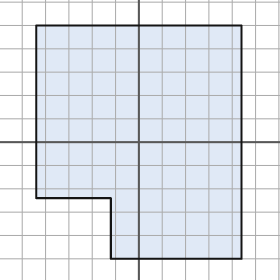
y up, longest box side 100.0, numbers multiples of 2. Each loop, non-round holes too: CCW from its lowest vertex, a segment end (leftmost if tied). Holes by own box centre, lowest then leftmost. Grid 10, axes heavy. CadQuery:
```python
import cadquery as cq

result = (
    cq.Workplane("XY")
    .moveTo(-12.0, -50.0)
    .lineTo(44.0, -50.0)
    .lineTo(44.0, 50.0)
    .lineTo(-44.0, 50.0)
    .lineTo(-44.0, -24.0)
    .lineTo(-12.0, -24.0)
    .close()
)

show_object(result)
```